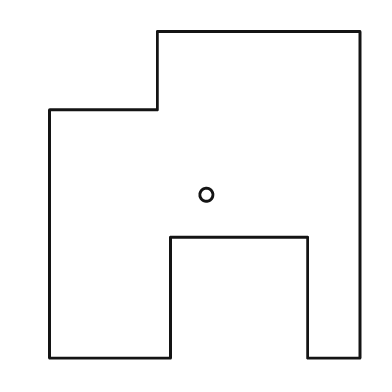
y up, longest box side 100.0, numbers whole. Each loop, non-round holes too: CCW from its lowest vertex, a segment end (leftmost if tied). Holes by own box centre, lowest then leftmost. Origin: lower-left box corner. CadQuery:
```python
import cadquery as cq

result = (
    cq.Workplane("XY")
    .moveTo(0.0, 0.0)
    .lineTo(37.0, 0.0)
    .lineTo(37.0, 37.0)
    .lineTo(79.0, 37.0)
    .lineTo(79.0, 0.0)
    .lineTo(95.0, 0.0)
    .lineTo(95.0, 100.0)
    .lineTo(33.0, 100.0)
    .lineTo(33.0, 76.0)
    .lineTo(0.0, 76.0)
    .close()
    .moveTo(48.0, 50.0)
    .circle(2.0)
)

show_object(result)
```